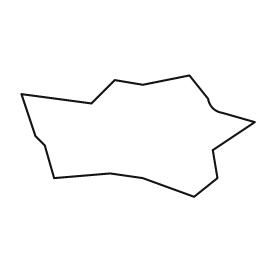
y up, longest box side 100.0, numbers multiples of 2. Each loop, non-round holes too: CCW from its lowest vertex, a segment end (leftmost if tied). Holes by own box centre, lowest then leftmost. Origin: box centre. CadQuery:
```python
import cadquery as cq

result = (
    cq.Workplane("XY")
    .moveTo(24.0, -26.0)
    .lineTo(34.0, -18.0)
    .lineTo(32.0, -6.0)
    .lineTo(50.0, 6.0)
    .lineTo(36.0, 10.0)
    .threePointArc((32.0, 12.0), (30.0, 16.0))
    .lineTo(22.0, 26.0)
    .lineTo(2.0, 22.0)
    .lineTo(-10.0, 24.0)
    .lineTo(-20.0, 14.0)
    .lineTo(-50.0, 18.0)
    .lineTo(-44.0, 0.0)
    .lineTo(-40.0, -4.0)
    .lineTo(-36.0, -18.0)
    .lineTo(-12.0, -16.0)
    .lineTo(2.0, -18.0)
    .close()
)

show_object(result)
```